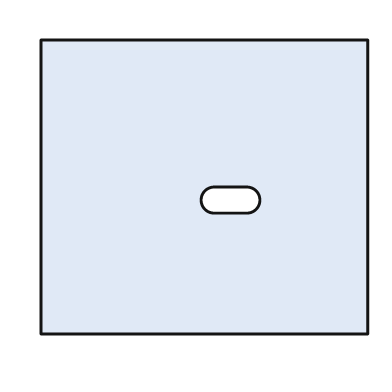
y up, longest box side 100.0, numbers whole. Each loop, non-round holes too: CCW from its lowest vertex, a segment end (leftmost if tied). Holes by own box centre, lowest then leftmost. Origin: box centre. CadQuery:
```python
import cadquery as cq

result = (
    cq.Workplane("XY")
    .moveTo(-50.0, -45.0)
    .lineTo(50.0, -45.0)
    .lineTo(50.0, 45.0)
    .lineTo(-50.0, 45.0)
    .close()
    .moveTo(3.0, -8.0)
    .lineTo(13.0, -8.0)
    .threePointArc((17.0, -4.0), (13.0, 0.0))
    .lineTo(3.0, 0.0)
    .threePointArc((-1.0, -4.0), (3.0, -8.0))
    .close()
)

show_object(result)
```